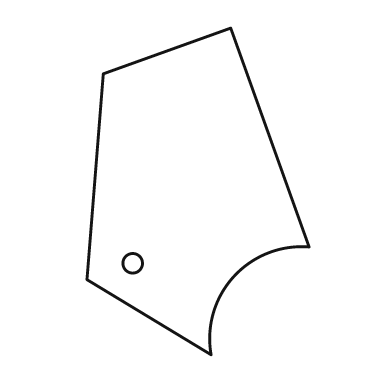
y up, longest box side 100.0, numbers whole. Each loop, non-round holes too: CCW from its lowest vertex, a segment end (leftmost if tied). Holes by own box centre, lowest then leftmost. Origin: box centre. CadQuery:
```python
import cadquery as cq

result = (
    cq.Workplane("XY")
    .moveTo(4.0, -50.0)
    .threePointArc((11.0, -26.0), (34.0, -17.0))
    .lineTo(10.0, 50.0)
    .lineTo(-29.0, 36.0)
    .lineTo(-34.0, -27.0)
    .close()
    .moveTo(-20.0, -22.0)
    .circle(3.0)
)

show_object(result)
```